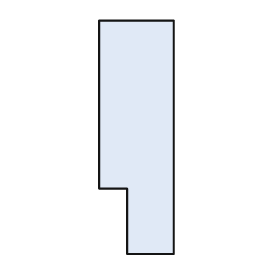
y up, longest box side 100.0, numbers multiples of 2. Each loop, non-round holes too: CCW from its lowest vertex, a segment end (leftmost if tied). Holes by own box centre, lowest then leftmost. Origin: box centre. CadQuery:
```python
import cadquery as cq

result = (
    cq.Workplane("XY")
    .moveTo(-4.0, -50.0)
    .lineTo(16.0, -50.0)
    .lineTo(16.0, 50.0)
    .lineTo(-16.0, 50.0)
    .lineTo(-16.0, -22.0)
    .lineTo(-4.0, -22.0)
    .close()
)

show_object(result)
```